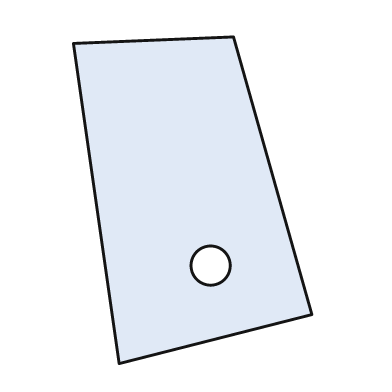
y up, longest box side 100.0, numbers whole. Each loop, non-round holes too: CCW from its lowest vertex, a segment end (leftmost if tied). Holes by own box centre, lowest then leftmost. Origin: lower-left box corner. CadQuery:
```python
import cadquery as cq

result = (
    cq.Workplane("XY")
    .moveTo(14.0, 0.0)
    .lineTo(73.0, 15.0)
    .lineTo(49.0, 100.0)
    .lineTo(0.0, 98.0)
    .close()
    .moveTo(42.0, 30.0)
    .circle(6.0)
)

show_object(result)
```